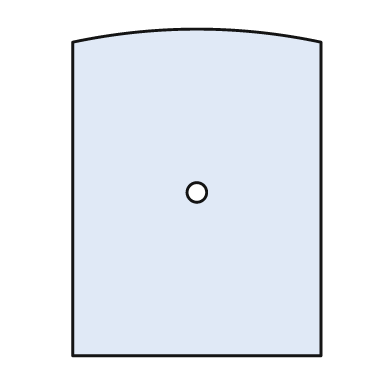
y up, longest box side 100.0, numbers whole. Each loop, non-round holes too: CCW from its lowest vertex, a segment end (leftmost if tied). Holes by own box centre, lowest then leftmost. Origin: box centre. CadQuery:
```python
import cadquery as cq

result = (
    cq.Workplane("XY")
    .moveTo(-38.0, -50.0)
    .lineTo(38.0, -50.0)
    .lineTo(38.0, 46.0)
    .threePointArc((0.0, 50.0), (-38.0, 46.0))
    .close()
    .moveTo(0.0, 0.0)
    .circle(3.0)
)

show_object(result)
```